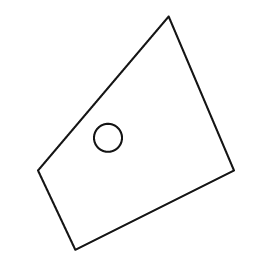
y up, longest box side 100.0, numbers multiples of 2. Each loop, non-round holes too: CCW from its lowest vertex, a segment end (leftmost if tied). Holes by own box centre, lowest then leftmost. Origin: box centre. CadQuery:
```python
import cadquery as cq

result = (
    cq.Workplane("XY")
    .moveTo(-26.0, -50.0)
    .lineTo(42.0, -16.0)
    .lineTo(14.0, 50.0)
    .lineTo(-42.0, -16.0)
    .close()
    .moveTo(-12.0, -2.0)
    .circle(6.0)
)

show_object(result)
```